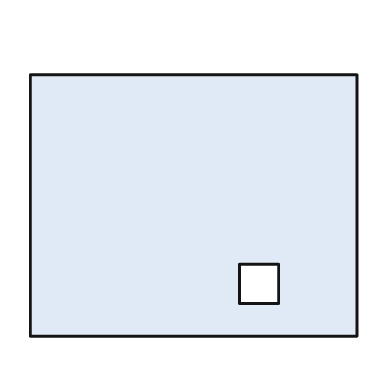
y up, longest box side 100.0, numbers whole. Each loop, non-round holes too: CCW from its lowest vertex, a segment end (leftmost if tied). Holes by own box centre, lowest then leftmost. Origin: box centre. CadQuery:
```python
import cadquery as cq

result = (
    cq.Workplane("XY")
    .moveTo(-50.0, -40.0)
    .lineTo(50.0, -40.0)
    .lineTo(50.0, 40.0)
    .lineTo(-50.0, 40.0)
    .close()
    .moveTo(14.0, -30.0)
    .lineTo(26.0, -30.0)
    .lineTo(26.0, -18.0)
    .lineTo(14.0, -18.0)
    .close()
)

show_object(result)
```